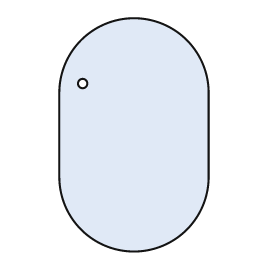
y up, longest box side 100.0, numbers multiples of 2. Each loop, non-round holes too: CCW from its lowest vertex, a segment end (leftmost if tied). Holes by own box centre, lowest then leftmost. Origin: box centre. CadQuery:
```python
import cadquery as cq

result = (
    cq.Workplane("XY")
    .moveTo(-32.0, -18.0)
    .threePointArc((0.0, -50.0), (32.0, -18.0))
    .lineTo(32.0, 18.0)
    .threePointArc((0.0, 50.0), (-32.0, 18.0))
    .close()
    .moveTo(-22.0, 22.0)
    .circle(2.0)
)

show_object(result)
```